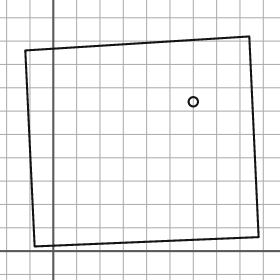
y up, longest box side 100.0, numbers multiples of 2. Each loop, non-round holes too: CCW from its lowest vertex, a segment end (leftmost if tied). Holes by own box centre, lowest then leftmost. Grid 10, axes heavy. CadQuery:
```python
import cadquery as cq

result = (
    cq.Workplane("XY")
    .moveTo(-8.0, 2.0)
    .lineTo(88.0, 6.0)
    .lineTo(84.0, 92.0)
    .lineTo(-12.0, 86.0)
    .close()
    .moveTo(60.0, 64.0)
    .circle(2.0)
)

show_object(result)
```